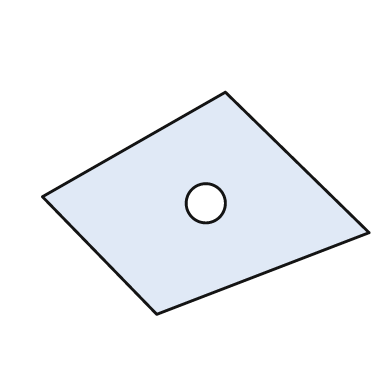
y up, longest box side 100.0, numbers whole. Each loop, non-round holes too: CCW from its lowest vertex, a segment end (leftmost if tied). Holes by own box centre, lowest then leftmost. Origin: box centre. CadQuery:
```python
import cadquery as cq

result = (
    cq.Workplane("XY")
    .moveTo(-15.0, -34.0)
    .lineTo(50.0, -9.0)
    .lineTo(6.0, 34.0)
    .lineTo(-50.0, 2.0)
    .close()
    .moveTo(0.0, 0.0)
    .circle(6.0)
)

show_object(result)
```